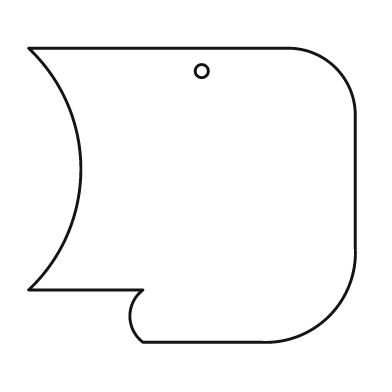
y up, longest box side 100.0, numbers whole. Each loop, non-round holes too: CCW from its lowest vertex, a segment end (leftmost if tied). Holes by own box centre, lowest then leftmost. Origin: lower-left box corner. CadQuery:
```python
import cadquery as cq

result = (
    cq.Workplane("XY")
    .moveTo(35.0, 0.0)
    .lineTo(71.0, 0.0)
    .threePointArc((92.0, 8.0), (100.0, 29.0))
    .lineTo(100.0, 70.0)
    .threePointArc((94.0, 84.0), (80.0, 90.0))
    .lineTo(0.0, 90.0)
    .threePointArc((16.0, 53.0), (0.0, 16.0))
    .lineTo(35.0, 16.0)
    .threePointArc((31.0, 8.0), (35.0, 0.0))
    .close()
    .moveTo(53.0, 83.0)
    .circle(2.0)
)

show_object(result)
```